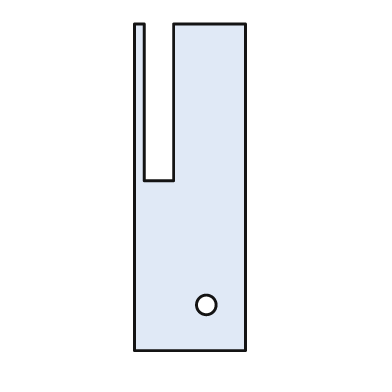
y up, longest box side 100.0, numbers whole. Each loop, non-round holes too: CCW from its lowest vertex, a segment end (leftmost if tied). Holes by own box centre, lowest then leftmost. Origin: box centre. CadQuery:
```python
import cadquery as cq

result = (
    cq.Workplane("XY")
    .moveTo(-17.0, -50.0)
    .lineTo(17.0, -50.0)
    .lineTo(17.0, 50.0)
    .lineTo(-5.0, 50.0)
    .lineTo(-5.0, 2.0)
    .lineTo(-14.0, 2.0)
    .lineTo(-14.0, 50.0)
    .lineTo(-17.0, 50.0)
    .close()
    .moveTo(5.0, -36.0)
    .circle(3.0)
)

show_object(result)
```